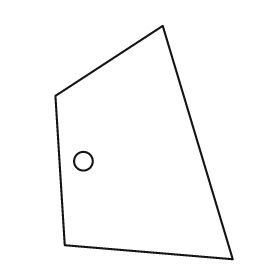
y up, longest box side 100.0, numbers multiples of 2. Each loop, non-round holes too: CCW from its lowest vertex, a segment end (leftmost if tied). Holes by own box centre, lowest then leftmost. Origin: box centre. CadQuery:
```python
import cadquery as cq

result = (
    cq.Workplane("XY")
    .moveTo(38.0, -50.0)
    .lineTo(8.0, 50.0)
    .lineTo(-38.0, 20.0)
    .lineTo(-34.0, -44.0)
    .close()
    .moveTo(-26.0, -8.0)
    .circle(4.0)
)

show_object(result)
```